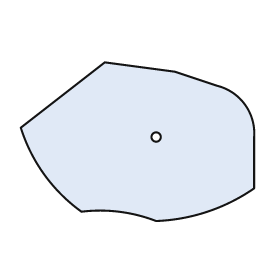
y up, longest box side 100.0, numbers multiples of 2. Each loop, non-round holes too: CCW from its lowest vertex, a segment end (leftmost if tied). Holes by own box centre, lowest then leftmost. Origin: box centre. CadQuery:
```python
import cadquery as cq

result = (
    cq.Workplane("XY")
    .moveTo(8.0, -34.0)
    .threePointArc((30.0, -30.0), (50.0, -20.0))
    .lineTo(50.0, 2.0)
    .threePointArc((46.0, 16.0), (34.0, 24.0))
    .lineTo(16.0, 30.0)
    .lineTo(-14.0, 34.0)
    .lineTo(-50.0, 6.0)
    .threePointArc((-40.0, -14.0), (-24.0, -30.0))
    .threePointArc((-8.0, -30.0), (8.0, -34.0))
    .close()
    .moveTo(8.0, 2.0)
    .circle(2.0)
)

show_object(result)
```